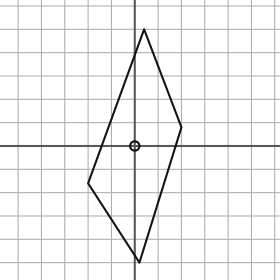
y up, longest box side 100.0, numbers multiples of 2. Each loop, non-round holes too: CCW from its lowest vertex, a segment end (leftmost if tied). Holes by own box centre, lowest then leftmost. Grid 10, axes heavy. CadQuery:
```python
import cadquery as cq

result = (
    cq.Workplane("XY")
    .moveTo(2.0, -50.0)
    .lineTo(20.0, 8.0)
    .lineTo(4.0, 50.0)
    .lineTo(-20.0, -16.0)
    .close()
    .moveTo(0.0, 0.0)
    .circle(2.0)
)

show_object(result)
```